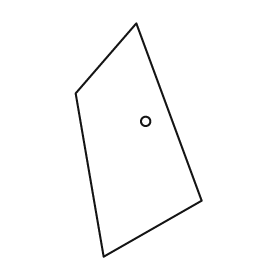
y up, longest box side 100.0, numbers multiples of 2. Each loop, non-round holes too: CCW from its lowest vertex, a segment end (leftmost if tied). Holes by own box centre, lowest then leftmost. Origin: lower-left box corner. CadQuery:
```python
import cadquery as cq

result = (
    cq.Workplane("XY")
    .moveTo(12.0, 0.0)
    .lineTo(54.0, 24.0)
    .lineTo(26.0, 100.0)
    .lineTo(0.0, 70.0)
    .close()
    .moveTo(30.0, 58.0)
    .circle(2.0)
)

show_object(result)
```